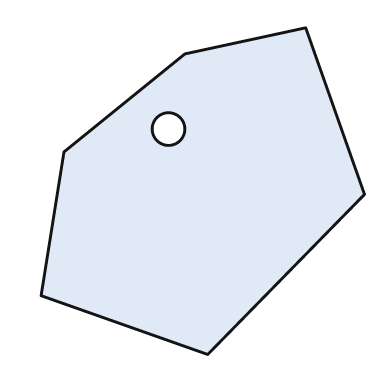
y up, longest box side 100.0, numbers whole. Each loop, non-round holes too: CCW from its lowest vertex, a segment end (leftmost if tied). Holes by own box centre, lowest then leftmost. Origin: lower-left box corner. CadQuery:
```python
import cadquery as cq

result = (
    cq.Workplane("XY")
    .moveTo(51.0, 0.0)
    .lineTo(99.0, 49.0)
    .lineTo(81.0, 100.0)
    .lineTo(44.0, 92.0)
    .lineTo(7.0, 62.0)
    .lineTo(0.0, 18.0)
    .close()
    .moveTo(39.0, 69.0)
    .circle(5.0)
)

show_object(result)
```